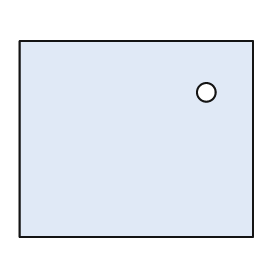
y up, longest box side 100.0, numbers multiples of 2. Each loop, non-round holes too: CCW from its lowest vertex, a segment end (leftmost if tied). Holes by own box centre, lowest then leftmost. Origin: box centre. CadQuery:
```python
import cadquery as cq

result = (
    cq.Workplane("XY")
    .moveTo(-50.0, -42.0)
    .lineTo(50.0, -42.0)
    .lineTo(50.0, 42.0)
    .lineTo(-50.0, 42.0)
    .close()
    .moveTo(30.0, 20.0)
    .circle(4.0)
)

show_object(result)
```